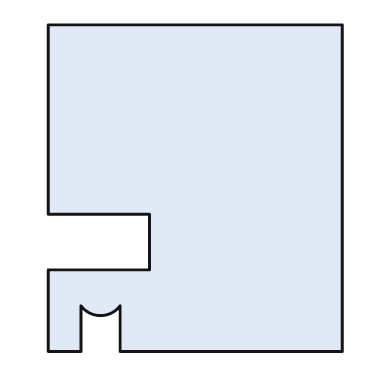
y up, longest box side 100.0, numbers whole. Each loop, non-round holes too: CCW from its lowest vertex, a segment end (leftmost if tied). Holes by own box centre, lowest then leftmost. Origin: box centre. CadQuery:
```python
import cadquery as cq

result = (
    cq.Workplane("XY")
    .moveTo(-45.0, -50.0)
    .lineTo(-35.0, -50.0)
    .lineTo(-35.0, -36.0)
    .threePointArc((-29.0, -39.0), (-23.0, -36.0))
    .lineTo(-23.0, -50.0)
    .lineTo(45.0, -50.0)
    .lineTo(45.0, 50.0)
    .lineTo(-45.0, 50.0)
    .lineTo(-45.0, -8.0)
    .lineTo(-14.0, -8.0)
    .lineTo(-14.0, -25.0)
    .lineTo(-45.0, -25.0)
    .close()
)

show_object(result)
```